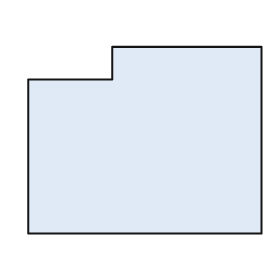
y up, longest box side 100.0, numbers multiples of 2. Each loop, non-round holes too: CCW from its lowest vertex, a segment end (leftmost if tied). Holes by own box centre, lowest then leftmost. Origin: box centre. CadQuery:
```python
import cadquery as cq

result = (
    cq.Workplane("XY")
    .moveTo(-50.0, -40.0)
    .lineTo(50.0, -40.0)
    .lineTo(50.0, 40.0)
    .lineTo(-14.0, 40.0)
    .lineTo(-14.0, 26.0)
    .lineTo(-50.0, 26.0)
    .close()
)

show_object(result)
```